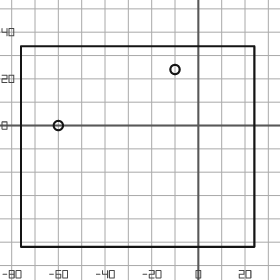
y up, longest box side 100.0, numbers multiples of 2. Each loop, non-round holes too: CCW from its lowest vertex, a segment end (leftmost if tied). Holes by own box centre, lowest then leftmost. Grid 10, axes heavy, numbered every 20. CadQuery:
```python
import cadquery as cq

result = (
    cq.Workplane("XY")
    .moveTo(-76.0, -52.0)
    .lineTo(24.0, -52.0)
    .lineTo(24.0, 34.0)
    .lineTo(-76.0, 34.0)
    .close()
    .moveTo(-60.0, 0.0)
    .circle(2.0)
    .moveTo(-10.0, 24.0)
    .circle(2.0)
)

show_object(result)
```